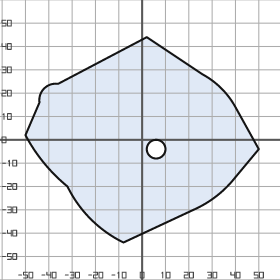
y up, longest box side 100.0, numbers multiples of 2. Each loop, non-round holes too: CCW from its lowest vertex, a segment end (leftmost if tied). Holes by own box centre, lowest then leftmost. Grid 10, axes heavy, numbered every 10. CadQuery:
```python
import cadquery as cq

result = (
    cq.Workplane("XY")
    .moveTo(-8.0, -44.0)
    .lineTo(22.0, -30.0)
    .threePointArc((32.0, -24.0), (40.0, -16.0))
    .lineTo(50.0, -4.0)
    .lineTo(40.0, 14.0)
    .threePointArc((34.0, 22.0), (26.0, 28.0))
    .lineTo(2.0, 44.0)
    .lineTo(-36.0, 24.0)
    .threePointArc((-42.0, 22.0), (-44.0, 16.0))
    .lineTo(-50.0, 2.0)
    .threePointArc((-42.0, -10.0), (-32.0, -20.0))
    .threePointArc((-22.0, -34.0), (-8.0, -44.0))
    .close()
    .moveTo(6.0, -4.0)
    .circle(4.0)
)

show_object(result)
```